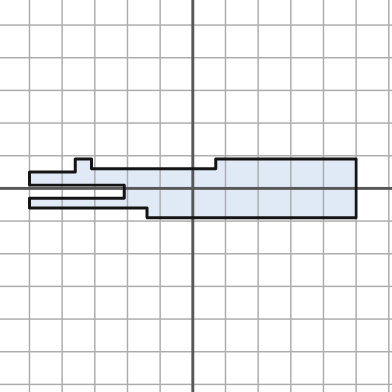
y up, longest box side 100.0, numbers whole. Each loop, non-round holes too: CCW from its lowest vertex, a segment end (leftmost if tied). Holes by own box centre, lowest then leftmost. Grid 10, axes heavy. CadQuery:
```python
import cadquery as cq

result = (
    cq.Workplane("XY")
    .moveTo(-14.0, -9.0)
    .lineTo(50.0, -9.0)
    .lineTo(50.0, 9.0)
    .lineTo(7.0, 9.0)
    .lineTo(7.0, 6.0)
    .lineTo(-31.0, 6.0)
    .lineTo(-31.0, 9.0)
    .lineTo(-36.0, 9.0)
    .lineTo(-36.0, 5.0)
    .lineTo(-50.0, 5.0)
    .lineTo(-50.0, 1.0)
    .lineTo(-21.0, 1.0)
    .lineTo(-21.0, -3.0)
    .lineTo(-50.0, -3.0)
    .lineTo(-50.0, -6.0)
    .lineTo(-14.0, -6.0)
    .close()
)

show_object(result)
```